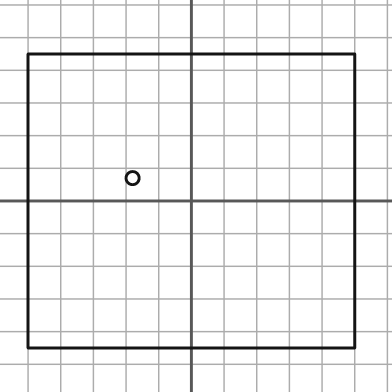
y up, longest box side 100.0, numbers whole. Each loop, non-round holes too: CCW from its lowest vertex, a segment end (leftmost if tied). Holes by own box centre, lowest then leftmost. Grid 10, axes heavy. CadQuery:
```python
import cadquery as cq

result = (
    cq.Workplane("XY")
    .moveTo(-50.0, -45.0)
    .lineTo(50.0, -45.0)
    .lineTo(50.0, 45.0)
    .lineTo(-50.0, 45.0)
    .close()
    .moveTo(-18.0, 7.0)
    .circle(2.0)
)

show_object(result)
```